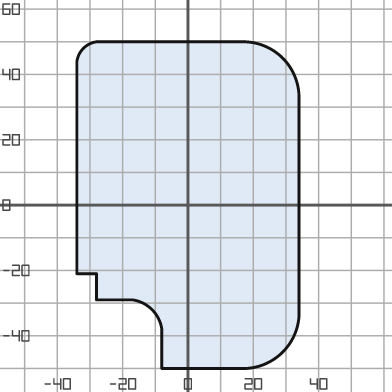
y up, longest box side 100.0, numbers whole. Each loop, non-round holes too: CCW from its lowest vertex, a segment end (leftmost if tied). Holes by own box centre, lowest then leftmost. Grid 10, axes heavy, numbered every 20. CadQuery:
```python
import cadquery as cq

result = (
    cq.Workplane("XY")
    .moveTo(-8.0, -50.0)
    .lineTo(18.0, -50.0)
    .threePointArc((29.0, -45.0), (34.0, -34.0))
    .lineTo(34.0, 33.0)
    .threePointArc((29.0, 45.0), (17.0, 50.0))
    .lineTo(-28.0, 50.0)
    .threePointArc((-32.0, 48.0), (-34.0, 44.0))
    .lineTo(-34.0, -21.0)
    .lineTo(-28.0, -21.0)
    .lineTo(-28.0, -29.0)
    .lineTo(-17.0, -29.0)
    .threePointArc((-11.0, -32.0), (-8.0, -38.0))
    .close()
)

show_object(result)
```